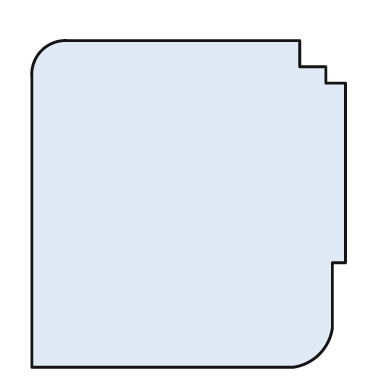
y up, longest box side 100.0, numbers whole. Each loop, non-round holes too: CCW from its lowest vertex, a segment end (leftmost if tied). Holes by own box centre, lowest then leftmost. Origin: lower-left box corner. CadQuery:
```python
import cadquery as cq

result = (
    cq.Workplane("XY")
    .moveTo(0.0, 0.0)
    .lineTo(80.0, 0.0)
    .threePointArc((88.0, 4.0), (92.0, 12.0))
    .lineTo(92.0, 32.0)
    .lineTo(96.0, 32.0)
    .lineTo(96.0, 87.0)
    .lineTo(90.0, 87.0)
    .lineTo(90.0, 92.0)
    .lineTo(82.0, 92.0)
    .lineTo(82.0, 100.0)
    .lineTo(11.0, 100.0)
    .threePointArc((3.0, 97.0), (0.0, 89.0))
    .close()
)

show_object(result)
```